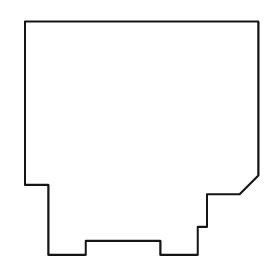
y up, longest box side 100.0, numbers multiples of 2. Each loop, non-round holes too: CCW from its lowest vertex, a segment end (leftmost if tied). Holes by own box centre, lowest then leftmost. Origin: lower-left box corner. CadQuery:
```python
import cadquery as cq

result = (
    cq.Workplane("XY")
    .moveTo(10.0, 0.0)
    .lineTo(26.0, 0.0)
    .lineTo(26.0, 6.0)
    .lineTo(58.0, 6.0)
    .lineTo(58.0, 0.0)
    .lineTo(74.0, 0.0)
    .lineTo(74.0, 12.0)
    .lineTo(78.0, 12.0)
    .lineTo(78.0, 26.0)
    .lineTo(92.0, 26.0)
    .lineTo(100.0, 34.0)
    .lineTo(100.0, 100.0)
    .lineTo(0.0, 100.0)
    .lineTo(0.0, 30.0)
    .lineTo(10.0, 30.0)
    .close()
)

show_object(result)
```